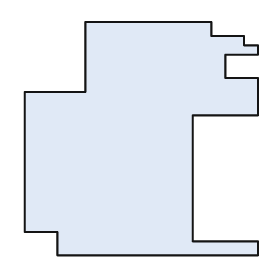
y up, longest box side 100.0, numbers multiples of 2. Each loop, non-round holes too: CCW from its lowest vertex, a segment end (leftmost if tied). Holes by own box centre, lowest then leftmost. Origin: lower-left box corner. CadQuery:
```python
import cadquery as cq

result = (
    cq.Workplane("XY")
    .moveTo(14.0, 0.0)
    .lineTo(100.0, 0.0)
    .lineTo(100.0, 6.0)
    .lineTo(72.0, 6.0)
    .lineTo(72.0, 60.0)
    .lineTo(100.0, 60.0)
    .lineTo(100.0, 76.0)
    .lineTo(86.0, 76.0)
    .lineTo(86.0, 86.0)
    .lineTo(100.0, 86.0)
    .lineTo(100.0, 90.0)
    .lineTo(94.0, 90.0)
    .lineTo(94.0, 94.0)
    .lineTo(80.0, 94.0)
    .lineTo(80.0, 100.0)
    .lineTo(26.0, 100.0)
    .lineTo(26.0, 70.0)
    .lineTo(0.0, 70.0)
    .lineTo(0.0, 10.0)
    .lineTo(14.0, 10.0)
    .close()
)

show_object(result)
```